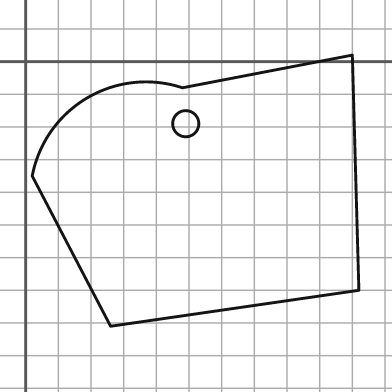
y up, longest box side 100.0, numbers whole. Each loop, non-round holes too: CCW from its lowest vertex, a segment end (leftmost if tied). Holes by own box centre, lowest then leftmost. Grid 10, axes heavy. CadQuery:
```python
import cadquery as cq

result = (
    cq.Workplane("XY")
    .moveTo(26.0, -81.0)
    .lineTo(102.0, -70.0)
    .lineTo(100.0, 2.0)
    .lineTo(48.0, -8.0)
    .threePointArc((19.0, -11.0), (2.0, -35.0))
    .close()
    .moveTo(49.0, -19.0)
    .circle(4.0)
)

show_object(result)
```